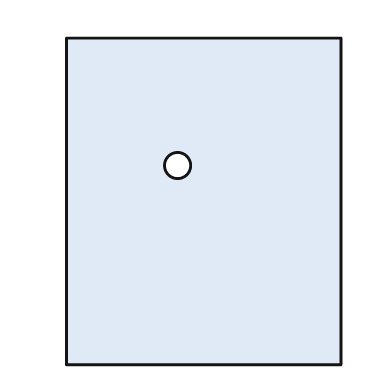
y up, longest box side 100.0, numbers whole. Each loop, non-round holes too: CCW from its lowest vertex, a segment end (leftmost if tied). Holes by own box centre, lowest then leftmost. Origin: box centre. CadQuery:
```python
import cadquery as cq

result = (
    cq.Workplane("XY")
    .moveTo(-42.0, -50.0)
    .lineTo(42.0, -50.0)
    .lineTo(42.0, 50.0)
    .lineTo(-42.0, 50.0)
    .close()
    .moveTo(-8.0, 11.0)
    .circle(4.0)
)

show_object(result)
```